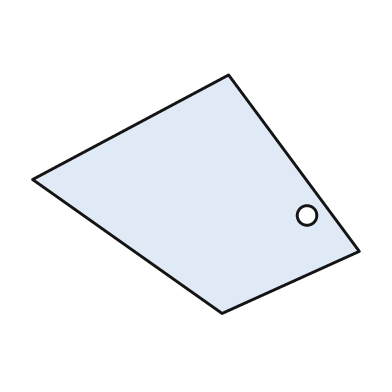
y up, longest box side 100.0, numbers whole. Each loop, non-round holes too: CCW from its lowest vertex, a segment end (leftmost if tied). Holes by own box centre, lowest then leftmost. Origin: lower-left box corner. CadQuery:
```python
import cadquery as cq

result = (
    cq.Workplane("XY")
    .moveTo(58.0, 0.0)
    .lineTo(100.0, 19.0)
    .lineTo(60.0, 73.0)
    .lineTo(0.0, 41.0)
    .close()
    .moveTo(84.0, 30.0)
    .circle(3.0)
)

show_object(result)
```